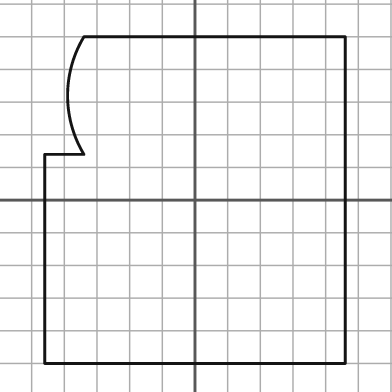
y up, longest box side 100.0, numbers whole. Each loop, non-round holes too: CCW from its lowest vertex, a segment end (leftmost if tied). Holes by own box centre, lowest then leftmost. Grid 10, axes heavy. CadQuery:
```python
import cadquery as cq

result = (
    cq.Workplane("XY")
    .moveTo(-46.0, -50.0)
    .lineTo(46.0, -50.0)
    .lineTo(46.0, 50.0)
    .lineTo(-34.0, 50.0)
    .threePointArc((-39.0, 32.0), (-34.0, 14.0))
    .lineTo(-46.0, 14.0)
    .close()
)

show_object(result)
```